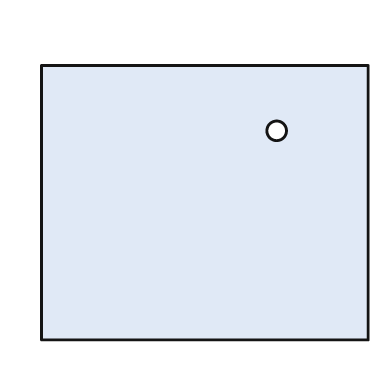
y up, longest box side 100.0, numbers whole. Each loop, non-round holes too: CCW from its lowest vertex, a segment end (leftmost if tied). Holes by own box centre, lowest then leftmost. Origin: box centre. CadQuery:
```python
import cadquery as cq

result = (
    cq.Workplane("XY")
    .moveTo(-50.0, -42.0)
    .lineTo(50.0, -42.0)
    .lineTo(50.0, 42.0)
    .lineTo(-50.0, 42.0)
    .close()
    .moveTo(22.0, 22.0)
    .circle(3.0)
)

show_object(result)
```